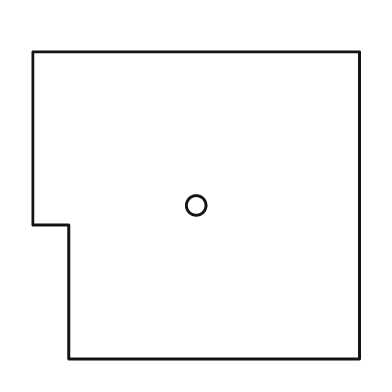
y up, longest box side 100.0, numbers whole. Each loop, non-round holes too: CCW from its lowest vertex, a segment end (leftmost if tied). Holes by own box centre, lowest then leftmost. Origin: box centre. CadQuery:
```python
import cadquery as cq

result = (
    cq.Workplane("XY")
    .moveTo(-39.0, -47.0)
    .lineTo(50.0, -47.0)
    .lineTo(50.0, 47.0)
    .lineTo(-50.0, 47.0)
    .lineTo(-50.0, -6.0)
    .lineTo(-39.0, -6.0)
    .close()
    .moveTo(0.0, 0.0)
    .circle(3.0)
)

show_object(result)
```